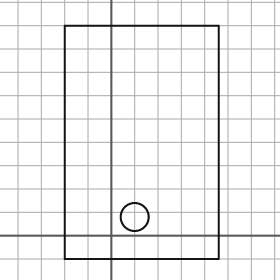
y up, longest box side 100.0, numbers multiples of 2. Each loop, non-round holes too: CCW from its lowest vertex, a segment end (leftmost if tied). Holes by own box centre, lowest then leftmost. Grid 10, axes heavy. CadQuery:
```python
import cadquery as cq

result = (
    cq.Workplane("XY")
    .moveTo(-20.0, -10.0)
    .lineTo(46.0, -10.0)
    .lineTo(46.0, 90.0)
    .lineTo(-20.0, 90.0)
    .close()
    .moveTo(10.0, 8.0)
    .circle(6.0)
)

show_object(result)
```